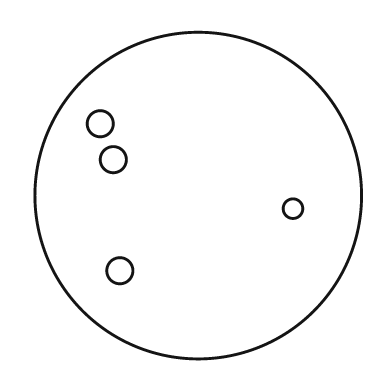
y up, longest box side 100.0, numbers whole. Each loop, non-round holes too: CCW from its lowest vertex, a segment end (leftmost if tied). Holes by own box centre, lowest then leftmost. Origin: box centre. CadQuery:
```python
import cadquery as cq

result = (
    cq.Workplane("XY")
    .moveTo(0.0, 0.0)
    .circle(50.0)
    .moveTo(-24.0, -23.0)
    .circle(4.0)
    .moveTo(29.0, -4.0)
    .circle(3.0)
    .moveTo(-26.0, 11.0)
    .circle(4.0)
    .moveTo(-30.0, 22.0)
    .circle(4.0)
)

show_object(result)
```